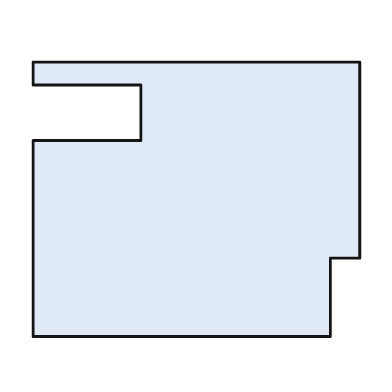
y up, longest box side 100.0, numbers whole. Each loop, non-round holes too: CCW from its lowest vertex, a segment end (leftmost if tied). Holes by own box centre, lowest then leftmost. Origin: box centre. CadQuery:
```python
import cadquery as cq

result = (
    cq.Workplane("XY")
    .moveTo(-50.0, -42.0)
    .lineTo(41.0, -42.0)
    .lineTo(41.0, -18.0)
    .lineTo(50.0, -18.0)
    .lineTo(50.0, 42.0)
    .lineTo(-50.0, 42.0)
    .lineTo(-50.0, 35.0)
    .lineTo(-17.0, 35.0)
    .lineTo(-17.0, 18.0)
    .lineTo(-50.0, 18.0)
    .close()
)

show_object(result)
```